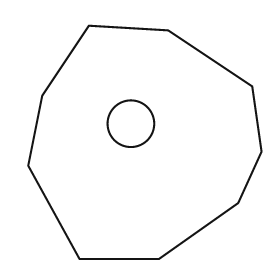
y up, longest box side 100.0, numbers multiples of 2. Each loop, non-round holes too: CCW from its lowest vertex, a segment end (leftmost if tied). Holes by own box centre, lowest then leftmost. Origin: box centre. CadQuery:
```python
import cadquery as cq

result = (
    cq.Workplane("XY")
    .moveTo(-28.0, -50.0)
    .lineTo(6.0, -50.0)
    .lineTo(40.0, -26.0)
    .lineTo(50.0, -4.0)
    .lineTo(46.0, 24.0)
    .lineTo(10.0, 48.0)
    .lineTo(-24.0, 50.0)
    .lineTo(-44.0, 20.0)
    .lineTo(-50.0, -10.0)
    .close()
    .moveTo(-6.0, 8.0)
    .circle(10.0)
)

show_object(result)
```